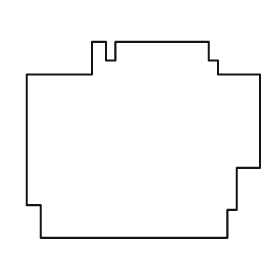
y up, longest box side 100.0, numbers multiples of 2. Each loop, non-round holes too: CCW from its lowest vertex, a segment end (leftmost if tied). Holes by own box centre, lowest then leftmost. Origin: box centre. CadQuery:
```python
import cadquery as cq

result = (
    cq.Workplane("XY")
    .moveTo(-44.0, -42.0)
    .lineTo(36.0, -42.0)
    .lineTo(36.0, -30.0)
    .lineTo(40.0, -30.0)
    .lineTo(40.0, -12.0)
    .lineTo(50.0, -12.0)
    .lineTo(50.0, 28.0)
    .lineTo(32.0, 28.0)
    .lineTo(32.0, 34.0)
    .lineTo(28.0, 34.0)
    .lineTo(28.0, 42.0)
    .lineTo(-12.0, 42.0)
    .lineTo(-12.0, 34.0)
    .lineTo(-16.0, 34.0)
    .lineTo(-16.0, 42.0)
    .lineTo(-22.0, 42.0)
    .lineTo(-22.0, 28.0)
    .lineTo(-50.0, 28.0)
    .lineTo(-50.0, -28.0)
    .lineTo(-44.0, -28.0)
    .close()
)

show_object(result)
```